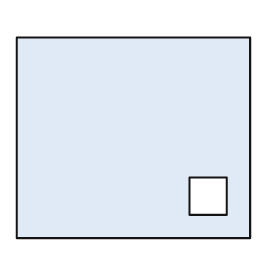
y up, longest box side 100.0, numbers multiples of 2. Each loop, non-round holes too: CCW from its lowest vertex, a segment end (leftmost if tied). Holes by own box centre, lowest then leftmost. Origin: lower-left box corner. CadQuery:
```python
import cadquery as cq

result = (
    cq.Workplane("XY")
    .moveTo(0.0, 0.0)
    .lineTo(100.0, 0.0)
    .lineTo(100.0, 86.0)
    .lineTo(0.0, 86.0)
    .close()
    .moveTo(74.0, 10.0)
    .lineTo(90.0, 10.0)
    .lineTo(90.0, 26.0)
    .lineTo(74.0, 26.0)
    .close()
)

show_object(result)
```